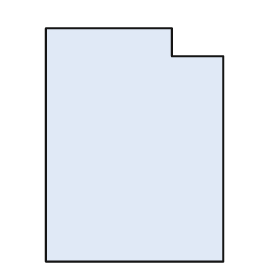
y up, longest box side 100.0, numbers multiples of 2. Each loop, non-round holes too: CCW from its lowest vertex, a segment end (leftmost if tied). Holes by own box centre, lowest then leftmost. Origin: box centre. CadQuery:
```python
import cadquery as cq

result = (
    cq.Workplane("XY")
    .moveTo(-38.0, -50.0)
    .lineTo(38.0, -50.0)
    .lineTo(38.0, 38.0)
    .lineTo(16.0, 38.0)
    .lineTo(16.0, 50.0)
    .lineTo(-38.0, 50.0)
    .close()
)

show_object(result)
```